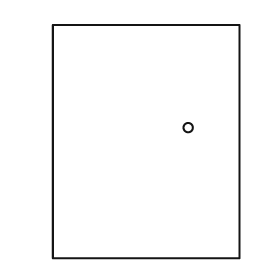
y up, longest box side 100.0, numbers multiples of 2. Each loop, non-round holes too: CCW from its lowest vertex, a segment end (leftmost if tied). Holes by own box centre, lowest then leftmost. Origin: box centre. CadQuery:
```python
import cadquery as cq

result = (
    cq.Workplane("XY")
    .moveTo(-40.0, -50.0)
    .lineTo(40.0, -50.0)
    .lineTo(40.0, 50.0)
    .lineTo(-40.0, 50.0)
    .close()
    .moveTo(18.0, 6.0)
    .circle(2.0)
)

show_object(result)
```